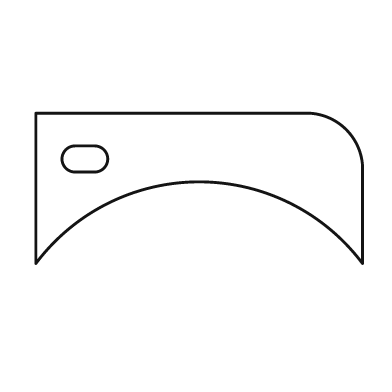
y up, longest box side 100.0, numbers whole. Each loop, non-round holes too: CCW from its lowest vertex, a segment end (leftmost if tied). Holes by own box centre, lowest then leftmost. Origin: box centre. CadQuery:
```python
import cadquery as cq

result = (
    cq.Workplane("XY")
    .moveTo(-50.0, -23.0)
    .threePointArc((0.0, 2.0), (50.0, -23.0))
    .lineTo(50.0, 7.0)
    .threePointArc((45.0, 18.0), (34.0, 23.0))
    .lineTo(-50.0, 23.0)
    .close()
    .moveTo(-38.0, 5.0)
    .lineTo(-32.0, 5.0)
    .threePointArc((-28.0, 9.0), (-32.0, 13.0))
    .lineTo(-38.0, 13.0)
    .threePointArc((-42.0, 9.0), (-38.0, 5.0))
    .close()
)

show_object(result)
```